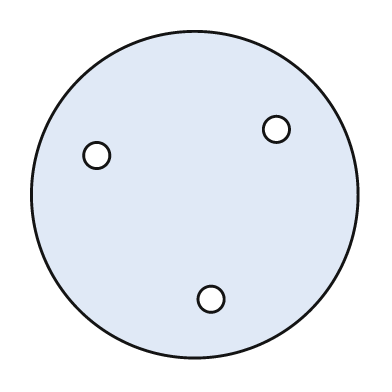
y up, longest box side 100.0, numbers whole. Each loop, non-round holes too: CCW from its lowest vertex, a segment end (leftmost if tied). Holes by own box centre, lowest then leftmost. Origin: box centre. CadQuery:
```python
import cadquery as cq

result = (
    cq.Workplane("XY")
    .moveTo(0.0, 0.0)
    .circle(50.0)
    .moveTo(5.0, -32.0)
    .circle(4.0)
    .moveTo(-30.0, 12.0)
    .circle(4.0)
    .moveTo(25.0, 20.0)
    .circle(4.0)
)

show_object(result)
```